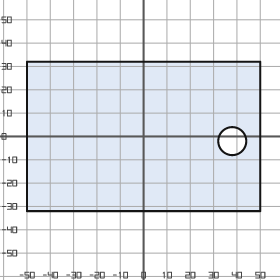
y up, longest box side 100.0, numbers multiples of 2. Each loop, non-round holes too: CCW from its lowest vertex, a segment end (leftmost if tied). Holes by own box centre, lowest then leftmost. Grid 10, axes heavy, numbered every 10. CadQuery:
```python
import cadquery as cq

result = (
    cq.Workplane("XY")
    .moveTo(-50.0, -32.0)
    .lineTo(50.0, -32.0)
    .lineTo(50.0, 32.0)
    .lineTo(-50.0, 32.0)
    .close()
    .moveTo(38.0, -2.0)
    .circle(6.0)
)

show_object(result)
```